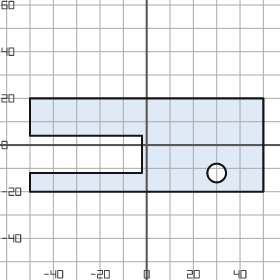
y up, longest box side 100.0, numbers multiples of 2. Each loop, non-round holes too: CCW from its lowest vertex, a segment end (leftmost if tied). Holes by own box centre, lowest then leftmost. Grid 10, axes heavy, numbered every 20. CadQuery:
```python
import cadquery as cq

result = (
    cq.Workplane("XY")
    .moveTo(-50.0, -20.0)
    .lineTo(50.0, -20.0)
    .lineTo(50.0, 20.0)
    .lineTo(-50.0, 20.0)
    .lineTo(-50.0, 4.0)
    .lineTo(-2.0, 4.0)
    .lineTo(-2.0, -12.0)
    .lineTo(-50.0, -12.0)
    .close()
    .moveTo(30.0, -12.0)
    .circle(4.0)
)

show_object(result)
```